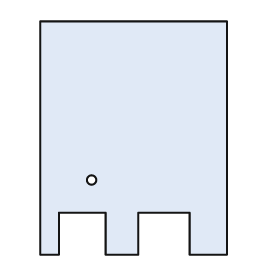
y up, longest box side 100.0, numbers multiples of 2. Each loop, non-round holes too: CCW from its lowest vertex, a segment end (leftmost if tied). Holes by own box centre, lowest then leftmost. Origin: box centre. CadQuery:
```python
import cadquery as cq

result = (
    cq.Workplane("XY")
    .moveTo(-40.0, -50.0)
    .lineTo(-32.0, -50.0)
    .lineTo(-32.0, -32.0)
    .lineTo(-12.0, -32.0)
    .lineTo(-12.0, -50.0)
    .lineTo(2.0, -50.0)
    .lineTo(2.0, -32.0)
    .lineTo(24.0, -32.0)
    .lineTo(24.0, -50.0)
    .lineTo(40.0, -50.0)
    .lineTo(40.0, 50.0)
    .lineTo(-40.0, 50.0)
    .close()
    .moveTo(-18.0, -18.0)
    .circle(2.0)
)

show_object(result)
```